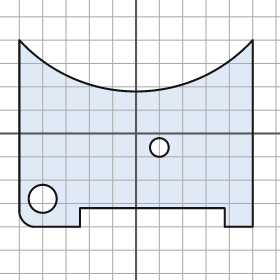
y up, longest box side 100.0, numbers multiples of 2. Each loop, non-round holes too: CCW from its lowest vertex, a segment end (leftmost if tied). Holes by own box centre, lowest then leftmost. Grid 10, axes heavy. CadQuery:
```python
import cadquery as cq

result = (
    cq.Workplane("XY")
    .moveTo(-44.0, -40.0)
    .lineTo(-24.0, -40.0)
    .lineTo(-24.0, -32.0)
    .lineTo(38.0, -32.0)
    .lineTo(38.0, -40.0)
    .lineTo(50.0, -40.0)
    .lineTo(50.0, 40.0)
    .threePointArc((0.0, 18.0), (-50.0, 40.0))
    .lineTo(-50.0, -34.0)
    .threePointArc((-48.0, -38.0), (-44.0, -40.0))
    .close()
    .moveTo(-40.0, -28.0)
    .circle(6.0)
    .moveTo(10.0, -6.0)
    .circle(4.0)
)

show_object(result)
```